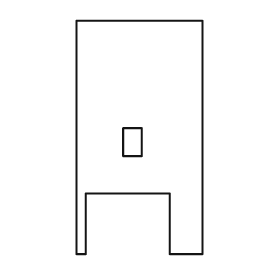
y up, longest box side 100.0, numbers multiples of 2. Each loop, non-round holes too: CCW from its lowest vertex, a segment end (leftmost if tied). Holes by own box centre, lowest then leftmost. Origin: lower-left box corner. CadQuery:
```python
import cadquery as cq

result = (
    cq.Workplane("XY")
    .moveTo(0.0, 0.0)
    .lineTo(4.0, 0.0)
    .lineTo(4.0, 26.0)
    .lineTo(40.0, 26.0)
    .lineTo(40.0, 0.0)
    .lineTo(54.0, 0.0)
    .lineTo(54.0, 100.0)
    .lineTo(0.0, 100.0)
    .close()
    .moveTo(20.0, 42.0)
    .lineTo(28.0, 42.0)
    .lineTo(28.0, 54.0)
    .lineTo(20.0, 54.0)
    .close()
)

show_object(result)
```